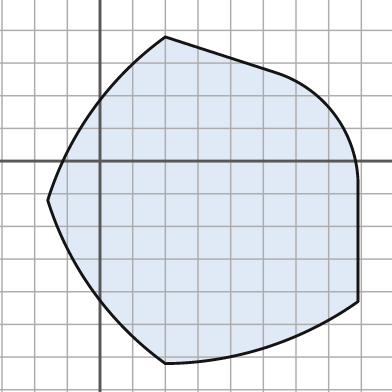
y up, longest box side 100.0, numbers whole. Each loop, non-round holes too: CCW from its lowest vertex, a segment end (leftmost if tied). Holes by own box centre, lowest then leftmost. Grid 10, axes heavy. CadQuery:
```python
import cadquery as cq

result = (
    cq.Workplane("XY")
    .moveTo(20.0, -62.0)
    .threePointArc((51.0, -57.0), (79.0, -43.0))
    .lineTo(79.0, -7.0)
    .threePointArc((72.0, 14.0), (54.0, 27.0))
    .lineTo(20.0, 38.0)
    .threePointArc((-2.0, 16.0), (-16.0, -12.0))
    .threePointArc((-2.0, -40.0), (20.0, -62.0))
    .close()
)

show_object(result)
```